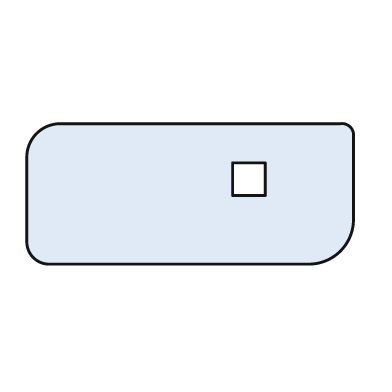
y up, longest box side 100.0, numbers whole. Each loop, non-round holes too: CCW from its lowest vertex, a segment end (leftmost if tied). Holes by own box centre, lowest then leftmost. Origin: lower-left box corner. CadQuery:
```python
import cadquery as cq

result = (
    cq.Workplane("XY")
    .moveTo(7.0, 0.0)
    .lineTo(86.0, 0.0)
    .threePointArc((96.0, 4.0), (100.0, 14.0))
    .lineTo(100.0, 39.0)
    .threePointArc((99.0, 42.0), (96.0, 43.0))
    .lineTo(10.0, 43.0)
    .threePointArc((3.0, 40.0), (0.0, 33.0))
    .lineTo(0.0, 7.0)
    .threePointArc((2.0, 2.0), (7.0, 0.0))
    .close()
    .moveTo(63.0, 21.0)
    .lineTo(73.0, 21.0)
    .lineTo(73.0, 31.0)
    .lineTo(63.0, 31.0)
    .close()
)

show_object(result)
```